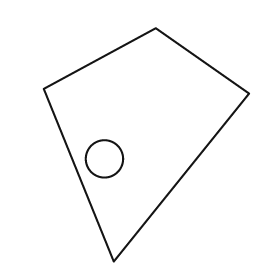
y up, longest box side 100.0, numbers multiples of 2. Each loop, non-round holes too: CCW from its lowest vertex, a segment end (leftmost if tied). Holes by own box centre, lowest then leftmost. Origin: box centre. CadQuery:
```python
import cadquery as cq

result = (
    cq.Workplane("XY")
    .moveTo(-14.0, -50.0)
    .lineTo(44.0, 22.0)
    .lineTo(4.0, 50.0)
    .lineTo(-44.0, 24.0)
    .close()
    .moveTo(-18.0, -6.0)
    .circle(8.0)
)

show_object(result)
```